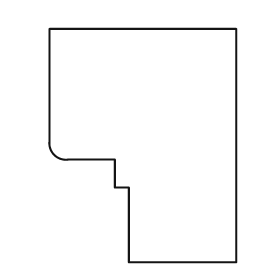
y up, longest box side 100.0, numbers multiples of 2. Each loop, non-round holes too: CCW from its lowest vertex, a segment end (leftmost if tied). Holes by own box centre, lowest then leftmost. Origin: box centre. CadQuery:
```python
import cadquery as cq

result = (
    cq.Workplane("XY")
    .moveTo(-6.0, -50.0)
    .lineTo(40.0, -50.0)
    .lineTo(40.0, 50.0)
    .lineTo(-40.0, 50.0)
    .lineTo(-40.0, 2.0)
    .threePointArc((-38.0, -4.0), (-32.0, -6.0))
    .lineTo(-12.0, -6.0)
    .lineTo(-12.0, -18.0)
    .lineTo(-6.0, -18.0)
    .close()
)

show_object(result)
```